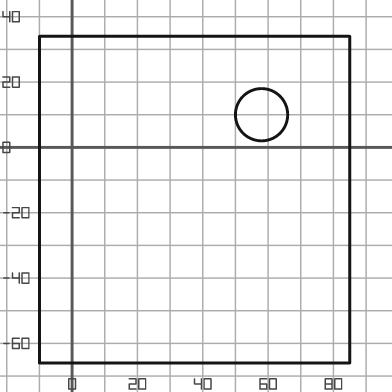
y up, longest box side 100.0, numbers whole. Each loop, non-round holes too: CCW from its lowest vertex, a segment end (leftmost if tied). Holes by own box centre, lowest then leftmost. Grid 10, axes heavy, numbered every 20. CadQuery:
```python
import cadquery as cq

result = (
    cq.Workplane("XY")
    .moveTo(-10.0, -66.0)
    .lineTo(85.0, -66.0)
    .lineTo(85.0, 34.0)
    .lineTo(-10.0, 34.0)
    .close()
    .moveTo(58.0, 10.0)
    .circle(8.0)
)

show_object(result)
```